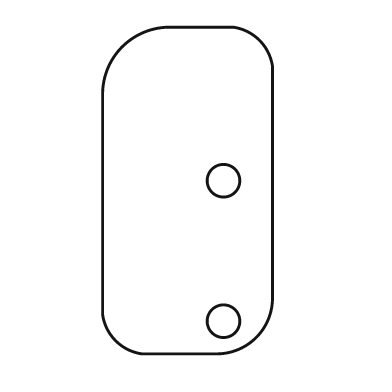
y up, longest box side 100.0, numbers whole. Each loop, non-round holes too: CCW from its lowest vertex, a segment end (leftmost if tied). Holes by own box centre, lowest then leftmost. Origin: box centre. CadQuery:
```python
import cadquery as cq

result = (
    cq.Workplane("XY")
    .moveTo(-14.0, -50.0)
    .lineTo(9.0, -50.0)
    .threePointArc((21.0, -45.0), (26.0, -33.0))
    .lineTo(26.0, 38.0)
    .threePointArc((22.0, 46.0), (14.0, 50.0))
    .lineTo(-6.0, 50.0)
    .threePointArc((-20.0, 44.0), (-26.0, 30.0))
    .lineTo(-26.0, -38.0)
    .threePointArc((-22.0, -46.0), (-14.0, -50.0))
    .close()
    .moveTo(11.0, -40.0)
    .circle(5.0)
    .moveTo(11.0, 3.0)
    .circle(5.0)
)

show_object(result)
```